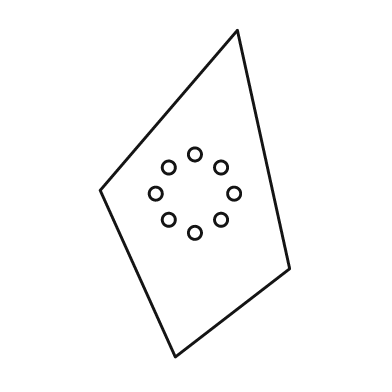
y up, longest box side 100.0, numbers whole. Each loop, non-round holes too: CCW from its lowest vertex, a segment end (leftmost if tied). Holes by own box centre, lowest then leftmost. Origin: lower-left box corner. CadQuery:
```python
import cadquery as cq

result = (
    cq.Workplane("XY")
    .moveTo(23.0, 0.0)
    .lineTo(58.0, 27.0)
    .lineTo(42.0, 100.0)
    .lineTo(0.0, 51.0)
    .close()
    .moveTo(29.0, 38.0)
    .circle(2.0)
    .moveTo(21.0, 42.0)
    .circle(2.0)
    .moveTo(37.0, 42.0)
    .circle(2.0)
    .moveTo(17.0, 50.0)
    .circle(2.0)
    .moveTo(41.0, 50.0)
    .circle(2.0)
    .moveTo(21.0, 58.0)
    .circle(2.0)
    .moveTo(37.0, 58.0)
    .circle(2.0)
    .moveTo(29.0, 62.0)
    .circle(2.0)
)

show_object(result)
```